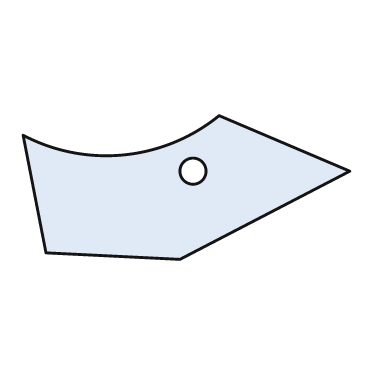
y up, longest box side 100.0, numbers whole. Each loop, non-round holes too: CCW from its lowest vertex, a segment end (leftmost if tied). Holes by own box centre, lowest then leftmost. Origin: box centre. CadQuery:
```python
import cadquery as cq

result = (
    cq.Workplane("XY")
    .moveTo(-2.0, -22.0)
    .lineTo(50.0, 5.0)
    .lineTo(10.0, 22.0)
    .threePointArc((-19.0, 10.0), (-50.0, 16.0))
    .lineTo(-43.0, -20.0)
    .close()
    .moveTo(2.0, 5.0)
    .circle(4.0)
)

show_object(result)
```